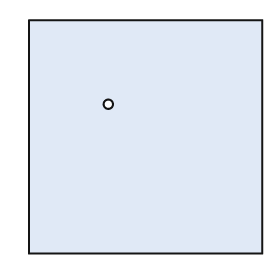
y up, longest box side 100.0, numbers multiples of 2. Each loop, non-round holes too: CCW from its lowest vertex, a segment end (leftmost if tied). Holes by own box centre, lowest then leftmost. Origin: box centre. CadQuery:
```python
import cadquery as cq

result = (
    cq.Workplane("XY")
    .moveTo(-50.0, -50.0)
    .lineTo(50.0, -50.0)
    .lineTo(50.0, 50.0)
    .lineTo(-50.0, 50.0)
    .close()
    .moveTo(-16.0, 14.0)
    .circle(2.0)
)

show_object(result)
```